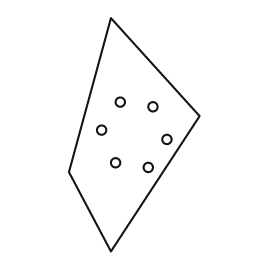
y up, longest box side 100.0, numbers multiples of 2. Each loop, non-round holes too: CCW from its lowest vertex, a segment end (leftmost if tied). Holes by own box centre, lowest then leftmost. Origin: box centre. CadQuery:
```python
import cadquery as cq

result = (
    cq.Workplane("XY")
    .moveTo(-10.0, -50.0)
    .lineTo(28.0, 8.0)
    .lineTo(-10.0, 50.0)
    .lineTo(-28.0, -16.0)
    .close()
    .moveTo(6.0, -14.0)
    .circle(2.0)
    .moveTo(-8.0, -12.0)
    .circle(2.0)
    .moveTo(14.0, -2.0)
    .circle(2.0)
    .moveTo(-14.0, 2.0)
    .circle(2.0)
    .moveTo(8.0, 12.0)
    .circle(2.0)
    .moveTo(-6.0, 14.0)
    .circle(2.0)
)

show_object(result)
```